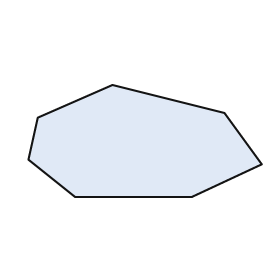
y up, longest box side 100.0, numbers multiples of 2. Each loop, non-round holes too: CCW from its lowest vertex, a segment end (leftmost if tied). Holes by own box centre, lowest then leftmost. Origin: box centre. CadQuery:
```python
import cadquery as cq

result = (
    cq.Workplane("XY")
    .moveTo(-30.0, -24.0)
    .lineTo(20.0, -24.0)
    .lineTo(50.0, -10.0)
    .lineTo(34.0, 12.0)
    .lineTo(-14.0, 24.0)
    .lineTo(-46.0, 10.0)
    .lineTo(-50.0, -8.0)
    .close()
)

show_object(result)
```